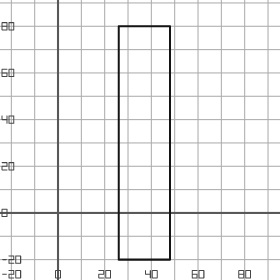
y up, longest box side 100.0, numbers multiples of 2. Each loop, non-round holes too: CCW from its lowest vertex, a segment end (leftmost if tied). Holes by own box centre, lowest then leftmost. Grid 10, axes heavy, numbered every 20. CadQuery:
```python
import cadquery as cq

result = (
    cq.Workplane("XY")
    .moveTo(26.0, -20.0)
    .lineTo(48.0, -20.0)
    .lineTo(48.0, 80.0)
    .lineTo(26.0, 80.0)
    .close()
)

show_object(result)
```